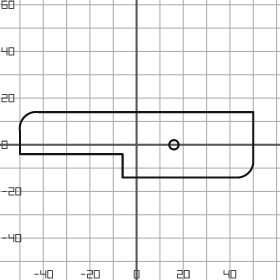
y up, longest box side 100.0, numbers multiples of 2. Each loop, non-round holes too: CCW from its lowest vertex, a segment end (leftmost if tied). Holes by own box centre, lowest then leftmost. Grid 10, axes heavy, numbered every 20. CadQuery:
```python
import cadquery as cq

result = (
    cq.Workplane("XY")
    .moveTo(-6.0, -14.0)
    .lineTo(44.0, -14.0)
    .threePointArc((48.0, -12.0), (50.0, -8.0))
    .lineTo(50.0, 14.0)
    .lineTo(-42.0, 14.0)
    .threePointArc((-48.0, 12.0), (-50.0, 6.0))
    .lineTo(-50.0, -4.0)
    .lineTo(-6.0, -4.0)
    .close()
    .moveTo(16.0, 0.0)
    .circle(2.0)
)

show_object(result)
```